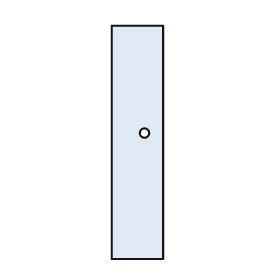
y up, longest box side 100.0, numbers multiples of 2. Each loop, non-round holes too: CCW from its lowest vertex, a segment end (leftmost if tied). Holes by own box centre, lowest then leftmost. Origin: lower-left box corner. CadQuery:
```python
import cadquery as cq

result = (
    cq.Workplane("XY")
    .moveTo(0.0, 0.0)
    .lineTo(22.0, 0.0)
    .lineTo(22.0, 100.0)
    .lineTo(0.0, 100.0)
    .close()
    .moveTo(14.0, 54.0)
    .circle(2.0)
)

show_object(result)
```